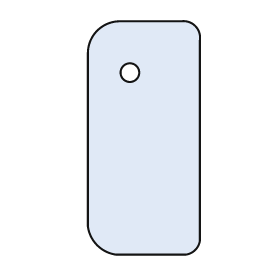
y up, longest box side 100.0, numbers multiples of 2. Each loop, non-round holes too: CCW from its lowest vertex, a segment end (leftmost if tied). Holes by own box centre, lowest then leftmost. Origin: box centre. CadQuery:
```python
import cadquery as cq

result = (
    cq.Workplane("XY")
    .moveTo(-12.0, -50.0)
    .lineTo(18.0, -50.0)
    .threePointArc((22.0, -48.0), (24.0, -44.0))
    .lineTo(24.0, 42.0)
    .threePointArc((22.0, 48.0), (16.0, 50.0))
    .lineTo(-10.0, 50.0)
    .threePointArc((-20.0, 46.0), (-24.0, 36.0))
    .lineTo(-24.0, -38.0)
    .threePointArc((-20.0, -46.0), (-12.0, -50.0))
    .close()
    .moveTo(-6.0, 28.0)
    .circle(4.0)
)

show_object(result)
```